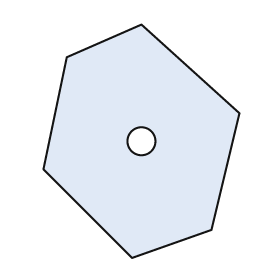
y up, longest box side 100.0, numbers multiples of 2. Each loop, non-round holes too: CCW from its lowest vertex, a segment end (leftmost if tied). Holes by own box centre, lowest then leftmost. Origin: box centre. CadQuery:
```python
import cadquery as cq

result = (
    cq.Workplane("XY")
    .moveTo(-4.0, -50.0)
    .lineTo(30.0, -38.0)
    .lineTo(42.0, 12.0)
    .lineTo(0.0, 50.0)
    .lineTo(-32.0, 36.0)
    .lineTo(-42.0, -12.0)
    .close()
    .moveTo(0.0, 0.0)
    .circle(6.0)
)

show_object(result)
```